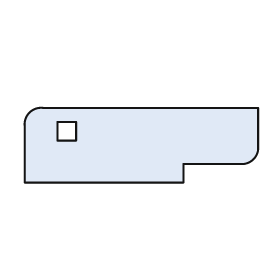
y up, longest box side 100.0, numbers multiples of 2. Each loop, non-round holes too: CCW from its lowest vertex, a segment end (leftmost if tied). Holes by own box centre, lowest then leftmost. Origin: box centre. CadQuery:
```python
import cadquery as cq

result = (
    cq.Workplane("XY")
    .moveTo(-50.0, -16.0)
    .lineTo(18.0, -16.0)
    .lineTo(18.0, -8.0)
    .lineTo(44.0, -8.0)
    .threePointArc((48.0, -6.0), (50.0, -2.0))
    .lineTo(50.0, 16.0)
    .lineTo(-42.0, 16.0)
    .threePointArc((-48.0, 14.0), (-50.0, 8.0))
    .close()
    .moveTo(-36.0, 2.0)
    .lineTo(-28.0, 2.0)
    .lineTo(-28.0, 10.0)
    .lineTo(-36.0, 10.0)
    .close()
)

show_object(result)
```